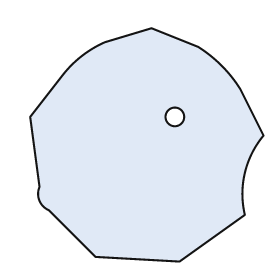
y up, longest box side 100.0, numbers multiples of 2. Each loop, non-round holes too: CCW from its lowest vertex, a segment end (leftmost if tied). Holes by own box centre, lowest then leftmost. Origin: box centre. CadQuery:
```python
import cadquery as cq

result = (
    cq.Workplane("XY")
    .moveTo(14.0, -50.0)
    .lineTo(42.0, -30.0)
    .threePointArc((42.0, -12.0), (50.0, 4.0))
    .lineTo(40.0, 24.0)
    .threePointArc((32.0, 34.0), (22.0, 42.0))
    .lineTo(2.0, 50.0)
    .lineTo(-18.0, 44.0)
    .threePointArc((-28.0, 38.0), (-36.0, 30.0))
    .lineTo(-50.0, 12.0)
    .lineTo(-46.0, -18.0)
    .threePointArc((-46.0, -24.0), (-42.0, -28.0))
    .lineTo(-22.0, -48.0)
    .close()
    .moveTo(12.0, 12.0)
    .circle(4.0)
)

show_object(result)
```